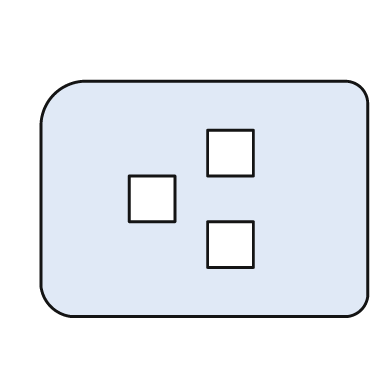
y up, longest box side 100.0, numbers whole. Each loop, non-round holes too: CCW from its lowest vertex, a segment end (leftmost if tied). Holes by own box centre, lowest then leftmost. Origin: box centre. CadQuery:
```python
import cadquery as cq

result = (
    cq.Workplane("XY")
    .moveTo(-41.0, -36.0)
    .lineTo(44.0, -36.0)
    .threePointArc((48.0, -34.0), (50.0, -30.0))
    .lineTo(50.0, 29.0)
    .threePointArc((48.0, 34.0), (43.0, 36.0))
    .lineTo(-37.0, 36.0)
    .threePointArc((-46.0, 32.0), (-50.0, 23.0))
    .lineTo(-50.0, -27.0)
    .threePointArc((-47.0, -33.0), (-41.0, -36.0))
    .close()
    .moveTo(1.0, -21.0)
    .lineTo(15.0, -21.0)
    .lineTo(15.0, -7.0)
    .lineTo(1.0, -7.0)
    .close()
    .moveTo(-23.0, -7.0)
    .lineTo(-9.0, -7.0)
    .lineTo(-9.0, 7.0)
    .lineTo(-23.0, 7.0)
    .close()
    .moveTo(1.0, 7.0)
    .lineTo(15.0, 7.0)
    .lineTo(15.0, 21.0)
    .lineTo(1.0, 21.0)
    .close()
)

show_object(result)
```